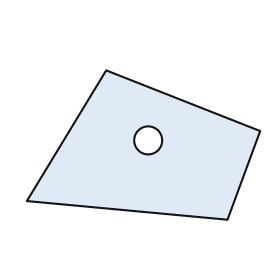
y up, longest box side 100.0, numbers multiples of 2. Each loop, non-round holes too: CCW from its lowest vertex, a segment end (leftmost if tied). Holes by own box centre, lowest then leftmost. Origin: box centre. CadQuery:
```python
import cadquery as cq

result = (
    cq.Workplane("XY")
    .moveTo(36.0, -32.0)
    .lineTo(50.0, 6.0)
    .lineTo(-16.0, 32.0)
    .lineTo(-50.0, -24.0)
    .close()
    .moveTo(2.0, 2.0)
    .circle(6.0)
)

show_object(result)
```